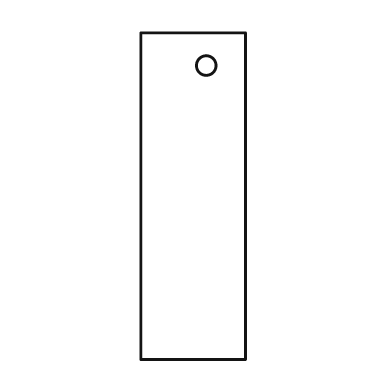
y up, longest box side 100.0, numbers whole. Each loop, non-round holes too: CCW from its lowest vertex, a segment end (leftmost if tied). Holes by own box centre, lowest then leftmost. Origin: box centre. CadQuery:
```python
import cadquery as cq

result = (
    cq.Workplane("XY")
    .moveTo(-16.0, -50.0)
    .lineTo(16.0, -50.0)
    .lineTo(16.0, 50.0)
    .lineTo(-16.0, 50.0)
    .close()
    .moveTo(4.0, 40.0)
    .circle(3.0)
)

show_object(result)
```